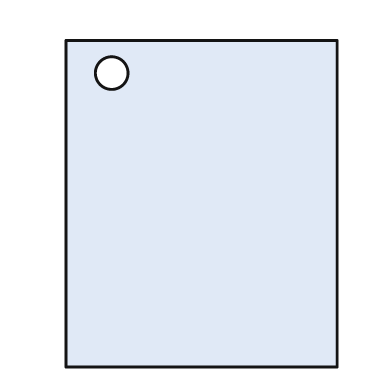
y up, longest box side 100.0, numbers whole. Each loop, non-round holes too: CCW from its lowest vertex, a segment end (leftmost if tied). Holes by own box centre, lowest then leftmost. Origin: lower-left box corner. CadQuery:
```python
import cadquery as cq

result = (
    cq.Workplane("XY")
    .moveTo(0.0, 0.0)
    .lineTo(83.0, 0.0)
    .lineTo(83.0, 100.0)
    .lineTo(0.0, 100.0)
    .close()
    .moveTo(14.0, 90.0)
    .circle(5.0)
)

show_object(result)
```